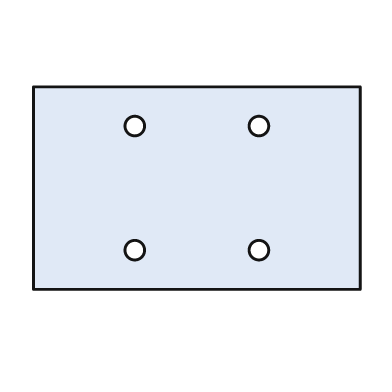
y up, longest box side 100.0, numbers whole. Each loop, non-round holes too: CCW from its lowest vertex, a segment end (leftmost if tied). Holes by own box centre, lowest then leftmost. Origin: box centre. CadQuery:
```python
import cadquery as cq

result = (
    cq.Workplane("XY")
    .moveTo(-50.0, -31.0)
    .lineTo(50.0, -31.0)
    .lineTo(50.0, 31.0)
    .lineTo(-50.0, 31.0)
    .close()
    .moveTo(-19.0, -19.0)
    .circle(3.0)
    .moveTo(19.0, -19.0)
    .circle(3.0)
    .moveTo(-19.0, 19.0)
    .circle(3.0)
    .moveTo(19.0, 19.0)
    .circle(3.0)
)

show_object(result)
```